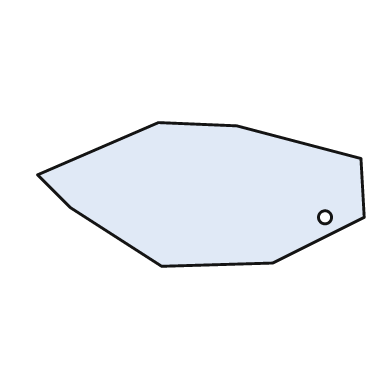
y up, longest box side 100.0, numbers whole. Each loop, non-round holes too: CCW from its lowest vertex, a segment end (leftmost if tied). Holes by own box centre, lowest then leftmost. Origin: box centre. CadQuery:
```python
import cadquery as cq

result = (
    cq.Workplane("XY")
    .moveTo(-12.0, -22.0)
    .lineTo(22.0, -21.0)
    .lineTo(50.0, -7.0)
    .lineTo(49.0, 11.0)
    .lineTo(11.0, 21.0)
    .lineTo(-13.0, 22.0)
    .lineTo(-50.0, 6.0)
    .lineTo(-40.0, -4.0)
    .close()
    .moveTo(38.0, -7.0)
    .circle(2.0)
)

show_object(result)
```